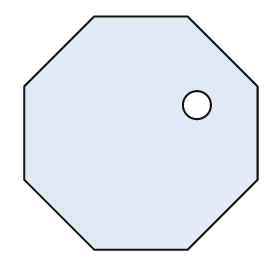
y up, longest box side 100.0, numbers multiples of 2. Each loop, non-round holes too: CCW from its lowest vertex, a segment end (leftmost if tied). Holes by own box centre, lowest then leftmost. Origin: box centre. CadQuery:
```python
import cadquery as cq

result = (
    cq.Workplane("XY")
    .moveTo(-20.0, -50.0)
    .lineTo(20.0, -50.0)
    .lineTo(50.0, -20.0)
    .lineTo(50.0, 20.0)
    .lineTo(20.0, 50.0)
    .lineTo(-20.0, 50.0)
    .lineTo(-50.0, 20.0)
    .lineTo(-50.0, -20.0)
    .close()
    .moveTo(24.0, 12.0)
    .circle(6.0)
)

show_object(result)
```